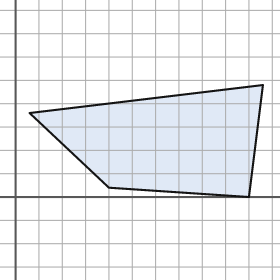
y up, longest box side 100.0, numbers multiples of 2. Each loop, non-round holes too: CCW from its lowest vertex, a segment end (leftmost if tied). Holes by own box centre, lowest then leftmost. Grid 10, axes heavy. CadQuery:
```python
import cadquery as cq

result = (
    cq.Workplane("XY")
    .moveTo(100.0, 0.0)
    .lineTo(106.0, 48.0)
    .lineTo(6.0, 36.0)
    .lineTo(40.0, 4.0)
    .close()
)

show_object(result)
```